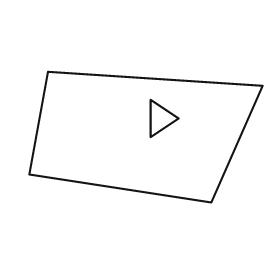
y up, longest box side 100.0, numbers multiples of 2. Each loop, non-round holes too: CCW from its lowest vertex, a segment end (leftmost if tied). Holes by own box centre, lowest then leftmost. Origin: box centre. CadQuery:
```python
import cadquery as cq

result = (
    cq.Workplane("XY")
    .moveTo(28.0, -28.0)
    .lineTo(50.0, 22.0)
    .lineTo(-42.0, 28.0)
    .lineTo(-50.0, -16.0)
    .close()
    .moveTo(2.0, 0.0)
    .lineTo(14.0, 8.0)
    .lineTo(2.0, 16.0)
    .close()
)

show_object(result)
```